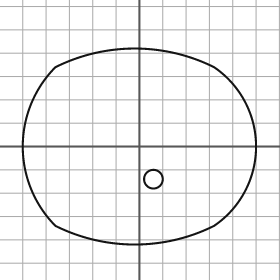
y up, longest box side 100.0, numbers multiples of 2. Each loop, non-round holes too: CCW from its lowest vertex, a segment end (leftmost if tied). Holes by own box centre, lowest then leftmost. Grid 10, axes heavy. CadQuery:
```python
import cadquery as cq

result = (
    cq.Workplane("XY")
    .moveTo(-36.0, -34.0)
    .threePointArc((-2.0, -42.0), (32.0, -34.0))
    .threePointArc((50.0, 0.0), (32.0, 34.0))
    .threePointArc((-2.0, 42.0), (-36.0, 34.0))
    .threePointArc((-50.0, 0.0), (-36.0, -34.0))
    .close()
    .moveTo(6.0, -14.0)
    .circle(4.0)
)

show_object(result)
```